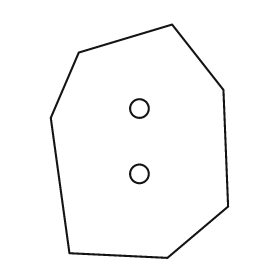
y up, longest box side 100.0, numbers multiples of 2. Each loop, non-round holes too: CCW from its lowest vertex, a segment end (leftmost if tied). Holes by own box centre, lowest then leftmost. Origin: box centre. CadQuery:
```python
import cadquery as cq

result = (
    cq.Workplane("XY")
    .moveTo(12.0, -50.0)
    .lineTo(38.0, -28.0)
    .lineTo(36.0, 22.0)
    .lineTo(14.0, 50.0)
    .lineTo(-26.0, 38.0)
    .lineTo(-38.0, 10.0)
    .lineTo(-30.0, -48.0)
    .close()
    .moveTo(0.0, -14.0)
    .circle(4.0)
    .moveTo(0.0, 14.0)
    .circle(4.0)
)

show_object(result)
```